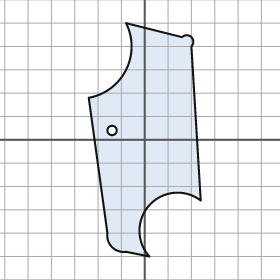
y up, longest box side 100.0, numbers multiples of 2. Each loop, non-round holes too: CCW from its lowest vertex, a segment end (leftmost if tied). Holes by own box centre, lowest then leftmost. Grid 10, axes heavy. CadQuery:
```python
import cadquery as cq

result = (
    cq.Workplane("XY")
    .moveTo(2.0, -50.0)
    .threePointArc((2.0, -28.0), (24.0, -26.0))
    .lineTo(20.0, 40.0)
    .threePointArc((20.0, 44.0), (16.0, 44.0))
    .lineTo(-8.0, 50.0)
    .threePointArc((-8.0, 30.0), (-24.0, 18.0))
    .lineTo(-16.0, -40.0)
    .threePointArc((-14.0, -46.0), (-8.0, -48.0))
    .close()
    .moveTo(-14.0, 4.0)
    .circle(2.0)
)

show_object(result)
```